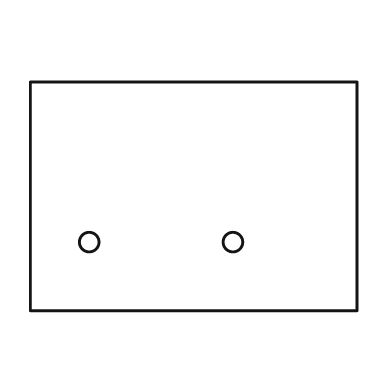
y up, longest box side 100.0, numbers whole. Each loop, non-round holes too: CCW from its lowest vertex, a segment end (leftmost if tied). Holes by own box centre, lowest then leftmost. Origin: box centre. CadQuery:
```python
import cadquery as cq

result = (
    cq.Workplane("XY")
    .moveTo(-50.0, -35.0)
    .lineTo(50.0, -35.0)
    .lineTo(50.0, 35.0)
    .lineTo(-50.0, 35.0)
    .close()
    .moveTo(-32.0, -14.0)
    .circle(3.0)
    .moveTo(12.0, -14.0)
    .circle(3.0)
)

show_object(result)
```